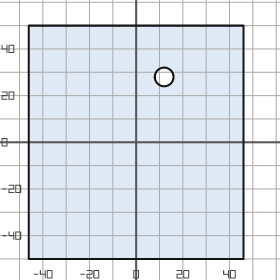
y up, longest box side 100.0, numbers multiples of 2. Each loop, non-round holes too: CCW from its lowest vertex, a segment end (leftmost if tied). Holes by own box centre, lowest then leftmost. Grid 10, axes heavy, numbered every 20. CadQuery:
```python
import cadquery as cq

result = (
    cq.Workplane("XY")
    .moveTo(-46.0, -50.0)
    .lineTo(46.0, -50.0)
    .lineTo(46.0, 50.0)
    .lineTo(-46.0, 50.0)
    .close()
    .moveTo(12.0, 28.0)
    .circle(4.0)
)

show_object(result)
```